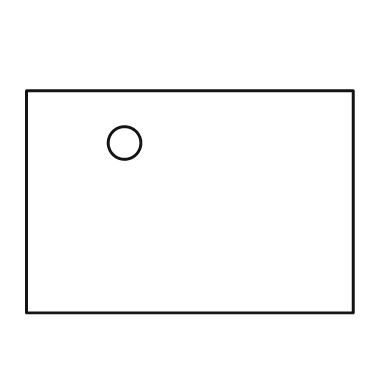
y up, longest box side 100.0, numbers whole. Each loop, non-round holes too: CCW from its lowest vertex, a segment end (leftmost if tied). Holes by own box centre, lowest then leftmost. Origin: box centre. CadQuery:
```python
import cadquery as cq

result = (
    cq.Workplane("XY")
    .moveTo(-50.0, -34.0)
    .lineTo(50.0, -34.0)
    .lineTo(50.0, 34.0)
    .lineTo(-50.0, 34.0)
    .close()
    .moveTo(-20.0, 18.0)
    .circle(5.0)
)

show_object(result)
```